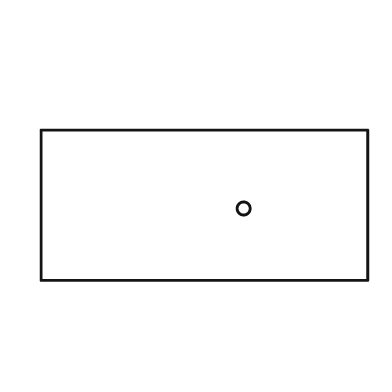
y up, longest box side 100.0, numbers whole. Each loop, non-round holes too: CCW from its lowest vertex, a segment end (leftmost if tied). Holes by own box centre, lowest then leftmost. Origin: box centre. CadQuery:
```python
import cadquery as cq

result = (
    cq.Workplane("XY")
    .moveTo(-50.0, -23.0)
    .lineTo(50.0, -23.0)
    .lineTo(50.0, 23.0)
    .lineTo(-50.0, 23.0)
    .close()
    .moveTo(12.0, -1.0)
    .circle(2.0)
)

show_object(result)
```